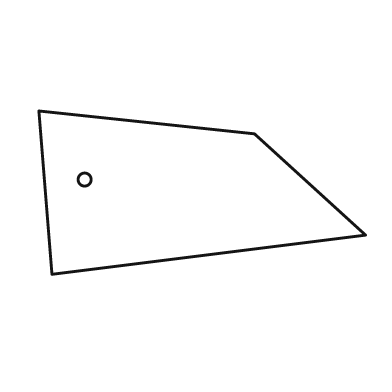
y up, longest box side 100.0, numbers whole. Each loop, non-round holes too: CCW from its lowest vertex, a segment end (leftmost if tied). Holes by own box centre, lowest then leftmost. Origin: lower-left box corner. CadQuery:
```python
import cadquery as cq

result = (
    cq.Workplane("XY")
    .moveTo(4.0, 0.0)
    .lineTo(100.0, 12.0)
    .lineTo(66.0, 43.0)
    .lineTo(0.0, 50.0)
    .close()
    .moveTo(14.0, 29.0)
    .circle(2.0)
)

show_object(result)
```